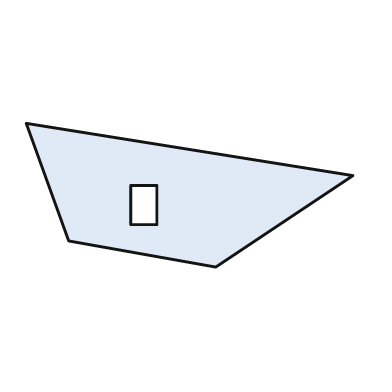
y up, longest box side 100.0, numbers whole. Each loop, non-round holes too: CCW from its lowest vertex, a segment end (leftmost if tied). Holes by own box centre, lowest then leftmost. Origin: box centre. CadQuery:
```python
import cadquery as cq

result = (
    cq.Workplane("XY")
    .moveTo(8.0, -22.0)
    .lineTo(50.0, 6.0)
    .lineTo(-50.0, 22.0)
    .lineTo(-37.0, -14.0)
    .close()
    .moveTo(-18.0, -9.0)
    .lineTo(-10.0, -9.0)
    .lineTo(-10.0, 3.0)
    .lineTo(-18.0, 3.0)
    .close()
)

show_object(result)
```